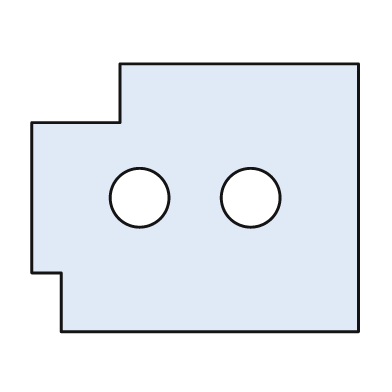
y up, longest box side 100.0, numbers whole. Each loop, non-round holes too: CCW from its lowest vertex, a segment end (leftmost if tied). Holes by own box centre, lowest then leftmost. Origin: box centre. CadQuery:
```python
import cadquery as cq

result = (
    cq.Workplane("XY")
    .moveTo(-41.0, -41.0)
    .lineTo(50.0, -41.0)
    .lineTo(50.0, 41.0)
    .lineTo(-23.0, 41.0)
    .lineTo(-23.0, 23.0)
    .lineTo(-50.0, 23.0)
    .lineTo(-50.0, -23.0)
    .lineTo(-41.0, -23.0)
    .close()
    .moveTo(-17.0, 0.0)
    .circle(9.0)
    .moveTo(17.0, 0.0)
    .circle(9.0)
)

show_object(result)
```